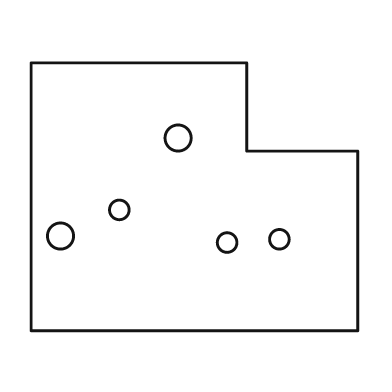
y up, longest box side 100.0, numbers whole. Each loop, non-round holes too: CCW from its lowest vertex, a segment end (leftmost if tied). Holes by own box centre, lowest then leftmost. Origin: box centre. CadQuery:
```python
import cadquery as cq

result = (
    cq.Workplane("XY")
    .moveTo(-50.0, -41.0)
    .lineTo(50.0, -41.0)
    .lineTo(50.0, 14.0)
    .lineTo(16.0, 14.0)
    .lineTo(16.0, 41.0)
    .lineTo(-50.0, 41.0)
    .close()
    .moveTo(10.0, -14.0)
    .circle(3.0)
    .moveTo(26.0, -13.0)
    .circle(3.0)
    .moveTo(-41.0, -12.0)
    .circle(4.0)
    .moveTo(-23.0, -4.0)
    .circle(3.0)
    .moveTo(-5.0, 18.0)
    .circle(4.0)
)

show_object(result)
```